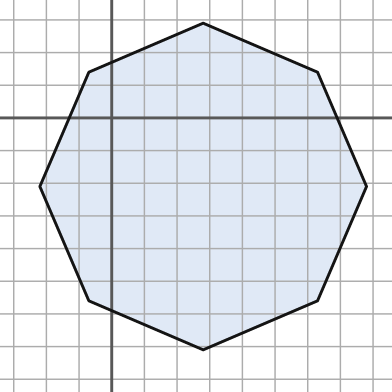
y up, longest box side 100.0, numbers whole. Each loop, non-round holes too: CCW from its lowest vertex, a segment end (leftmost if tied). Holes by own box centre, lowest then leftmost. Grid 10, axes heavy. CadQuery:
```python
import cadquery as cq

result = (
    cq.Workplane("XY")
    .moveTo(28.0, -71.0)
    .lineTo(63.0, -56.0)
    .lineTo(78.0, -21.0)
    .lineTo(63.0, 14.0)
    .lineTo(28.0, 29.0)
    .lineTo(-7.0, 14.0)
    .lineTo(-22.0, -21.0)
    .lineTo(-7.0, -56.0)
    .close()
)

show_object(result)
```